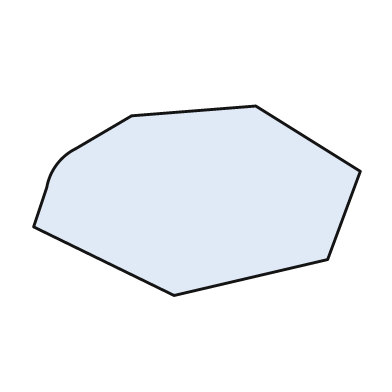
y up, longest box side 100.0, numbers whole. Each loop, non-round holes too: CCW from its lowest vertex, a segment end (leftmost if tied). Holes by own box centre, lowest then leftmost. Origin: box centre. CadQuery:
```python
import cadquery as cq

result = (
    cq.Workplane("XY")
    .moveTo(-7.0, -29.0)
    .lineTo(40.0, -18.0)
    .lineTo(50.0, 9.0)
    .lineTo(18.0, 29.0)
    .lineTo(-20.0, 26.0)
    .lineTo(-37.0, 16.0)
    .threePointArc((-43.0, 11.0), (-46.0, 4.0))
    .lineTo(-50.0, -8.0)
    .close()
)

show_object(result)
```